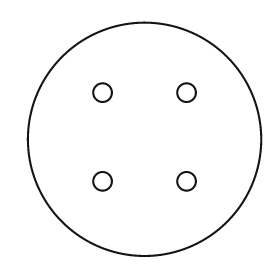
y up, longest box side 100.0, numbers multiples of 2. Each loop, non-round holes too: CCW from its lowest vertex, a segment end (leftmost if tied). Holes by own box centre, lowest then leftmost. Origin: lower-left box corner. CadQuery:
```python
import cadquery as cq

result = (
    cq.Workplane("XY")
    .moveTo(50.0, 50.0)
    .circle(50.0)
    .moveTo(32.0, 32.0)
    .circle(4.0)
    .moveTo(68.0, 32.0)
    .circle(4.0)
    .moveTo(32.0, 70.0)
    .circle(4.0)
    .moveTo(68.0, 70.0)
    .circle(4.0)
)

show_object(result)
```